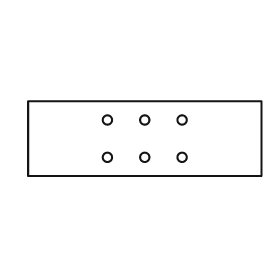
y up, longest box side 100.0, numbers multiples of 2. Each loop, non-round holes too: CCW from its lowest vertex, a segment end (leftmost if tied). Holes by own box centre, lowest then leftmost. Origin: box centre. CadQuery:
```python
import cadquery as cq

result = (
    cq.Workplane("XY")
    .moveTo(-50.0, -16.0)
    .lineTo(50.0, -16.0)
    .lineTo(50.0, 16.0)
    .lineTo(-50.0, 16.0)
    .close()
    .moveTo(-16.0, -8.0)
    .circle(2.0)
    .moveTo(0.0, -8.0)
    .circle(2.0)
    .moveTo(16.0, -8.0)
    .circle(2.0)
    .moveTo(-16.0, 8.0)
    .circle(2.0)
    .moveTo(0.0, 8.0)
    .circle(2.0)
    .moveTo(16.0, 8.0)
    .circle(2.0)
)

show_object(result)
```